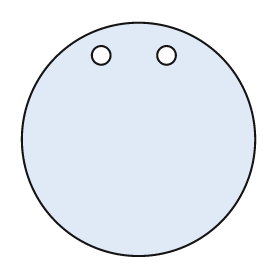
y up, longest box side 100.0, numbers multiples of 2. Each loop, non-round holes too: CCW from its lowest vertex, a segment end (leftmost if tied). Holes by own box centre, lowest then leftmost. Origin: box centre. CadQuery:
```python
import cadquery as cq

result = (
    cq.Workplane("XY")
    .moveTo(0.0, 0.0)
    .circle(50.0)
    .moveTo(-16.0, 36.0)
    .circle(4.0)
    .moveTo(12.0, 36.0)
    .circle(4.0)
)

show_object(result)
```